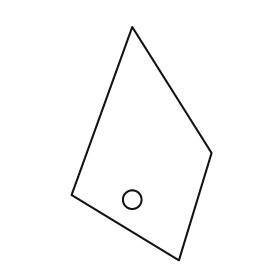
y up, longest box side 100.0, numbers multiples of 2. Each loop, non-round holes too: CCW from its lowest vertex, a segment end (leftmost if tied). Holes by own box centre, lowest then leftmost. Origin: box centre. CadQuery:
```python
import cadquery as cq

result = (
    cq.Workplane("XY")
    .moveTo(16.0, -50.0)
    .lineTo(30.0, -4.0)
    .lineTo(-4.0, 50.0)
    .lineTo(-30.0, -22.0)
    .close()
    .moveTo(-4.0, -24.0)
    .circle(4.0)
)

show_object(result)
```